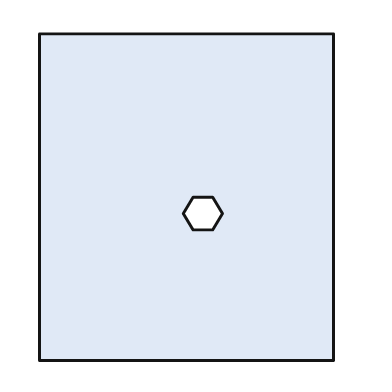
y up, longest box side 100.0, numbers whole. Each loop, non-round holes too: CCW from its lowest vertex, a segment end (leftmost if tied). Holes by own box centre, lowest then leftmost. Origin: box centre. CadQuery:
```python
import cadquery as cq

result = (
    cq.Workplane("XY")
    .moveTo(-45.0, -50.0)
    .lineTo(45.0, -50.0)
    .lineTo(45.0, 50.0)
    .lineTo(-45.0, 50.0)
    .close()
    .moveTo(2.0, -10.0)
    .lineTo(8.0, -10.0)
    .lineTo(11.0, -5.0)
    .lineTo(8.0, 0.0)
    .lineTo(2.0, 0.0)
    .lineTo(-1.0, -5.0)
    .close()
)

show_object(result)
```